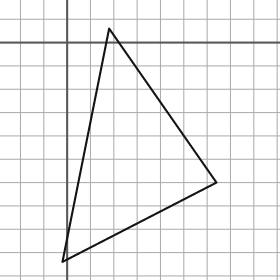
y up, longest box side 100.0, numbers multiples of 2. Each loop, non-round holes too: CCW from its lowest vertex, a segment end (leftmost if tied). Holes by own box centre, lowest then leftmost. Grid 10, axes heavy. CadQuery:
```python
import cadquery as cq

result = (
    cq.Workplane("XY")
    .moveTo(-2.0, -94.0)
    .lineTo(64.0, -60.0)
    .lineTo(18.0, 6.0)
    .close()
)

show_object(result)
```